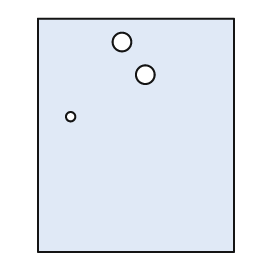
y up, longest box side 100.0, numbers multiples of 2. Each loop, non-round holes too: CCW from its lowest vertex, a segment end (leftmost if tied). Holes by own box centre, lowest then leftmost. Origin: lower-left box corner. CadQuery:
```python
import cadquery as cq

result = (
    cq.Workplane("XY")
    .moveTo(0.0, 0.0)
    .lineTo(84.0, 0.0)
    .lineTo(84.0, 100.0)
    .lineTo(0.0, 100.0)
    .close()
    .moveTo(14.0, 58.0)
    .circle(2.0)
    .moveTo(46.0, 76.0)
    .circle(4.0)
    .moveTo(36.0, 90.0)
    .circle(4.0)
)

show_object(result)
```